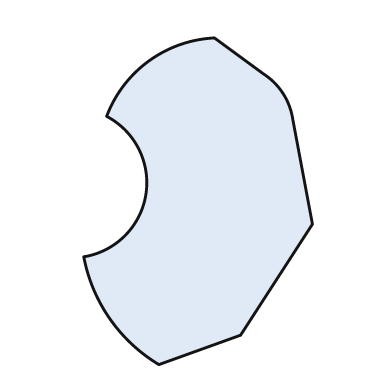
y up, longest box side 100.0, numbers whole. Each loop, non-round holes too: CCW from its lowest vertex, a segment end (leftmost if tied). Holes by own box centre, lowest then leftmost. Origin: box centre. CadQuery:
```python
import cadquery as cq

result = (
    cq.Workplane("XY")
    .moveTo(-12.0, -50.0)
    .lineTo(13.0, -41.0)
    .lineTo(35.0, -7.0)
    .lineTo(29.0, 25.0)
    .threePointArc((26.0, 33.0), (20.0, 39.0))
    .lineTo(5.0, 50.0)
    .threePointArc((-15.0, 43.0), (-28.0, 26.0))
    .threePointArc((-16.0, 2.0), (-35.0, -17.0))
    .threePointArc((-27.0, -36.0), (-12.0, -50.0))
    .close()
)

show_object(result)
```